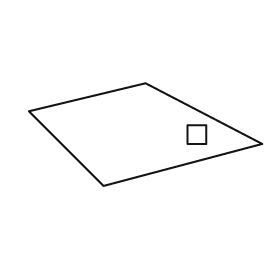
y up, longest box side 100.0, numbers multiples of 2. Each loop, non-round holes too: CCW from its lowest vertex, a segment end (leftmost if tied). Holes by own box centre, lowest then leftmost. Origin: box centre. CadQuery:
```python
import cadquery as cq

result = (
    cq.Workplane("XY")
    .moveTo(-18.0, -22.0)
    .lineTo(50.0, -4.0)
    .lineTo(0.0, 22.0)
    .lineTo(-50.0, 10.0)
    .close()
    .moveTo(18.0, -4.0)
    .lineTo(26.0, -4.0)
    .lineTo(26.0, 4.0)
    .lineTo(18.0, 4.0)
    .close()
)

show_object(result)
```